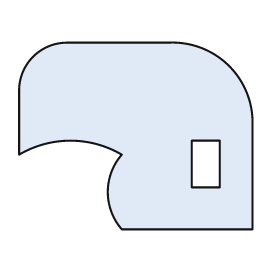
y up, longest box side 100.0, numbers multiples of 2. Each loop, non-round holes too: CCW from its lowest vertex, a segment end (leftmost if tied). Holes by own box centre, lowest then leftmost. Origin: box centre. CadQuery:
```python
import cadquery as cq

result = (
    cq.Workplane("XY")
    .moveTo(-6.0, -40.0)
    .lineTo(50.0, -40.0)
    .lineTo(50.0, 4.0)
    .threePointArc((40.0, 30.0), (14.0, 40.0))
    .lineTo(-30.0, 40.0)
    .threePointArc((-44.0, 34.0), (-50.0, 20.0))
    .lineTo(-50.0, -8.0)
    .threePointArc((-28.0, -2.0), (-6.0, -8.0))
    .threePointArc((-12.0, -24.0), (-6.0, -40.0))
    .close()
    .moveTo(24.0, -22.0)
    .lineTo(36.0, -22.0)
    .lineTo(36.0, -2.0)
    .lineTo(24.0, -2.0)
    .close()
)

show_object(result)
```